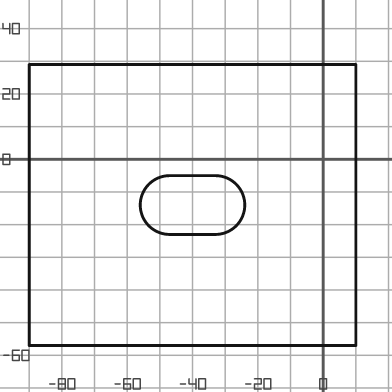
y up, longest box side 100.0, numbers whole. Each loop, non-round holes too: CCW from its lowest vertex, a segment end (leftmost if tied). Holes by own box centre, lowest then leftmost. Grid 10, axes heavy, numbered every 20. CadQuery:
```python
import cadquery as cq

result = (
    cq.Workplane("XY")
    .moveTo(-90.0, -57.0)
    .lineTo(10.0, -57.0)
    .lineTo(10.0, 29.0)
    .lineTo(-90.0, 29.0)
    .close()
    .moveTo(-47.0, -23.0)
    .lineTo(-33.0, -23.0)
    .threePointArc((-24.0, -14.0), (-33.0, -5.0))
    .lineTo(-47.0, -5.0)
    .threePointArc((-56.0, -14.0), (-47.0, -23.0))
    .close()
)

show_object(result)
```